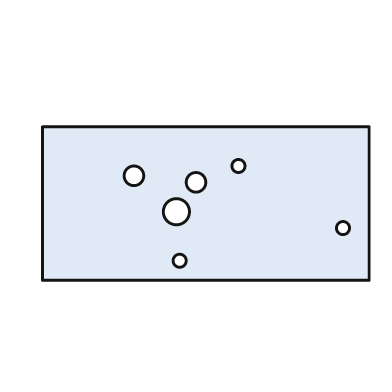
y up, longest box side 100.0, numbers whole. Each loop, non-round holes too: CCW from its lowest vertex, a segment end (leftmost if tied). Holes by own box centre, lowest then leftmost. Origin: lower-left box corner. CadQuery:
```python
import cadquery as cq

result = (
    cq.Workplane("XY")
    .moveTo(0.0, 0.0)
    .lineTo(100.0, 0.0)
    .lineTo(100.0, 47.0)
    .lineTo(0.0, 47.0)
    .close()
    .moveTo(42.0, 6.0)
    .circle(2.0)
    .moveTo(92.0, 16.0)
    .circle(2.0)
    .moveTo(41.0, 21.0)
    .circle(4.0)
    .moveTo(47.0, 30.0)
    .circle(3.0)
    .moveTo(28.0, 32.0)
    .circle(3.0)
    .moveTo(60.0, 35.0)
    .circle(2.0)
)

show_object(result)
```